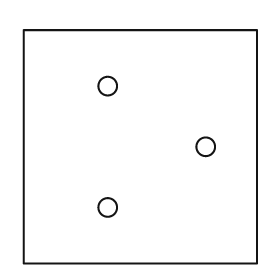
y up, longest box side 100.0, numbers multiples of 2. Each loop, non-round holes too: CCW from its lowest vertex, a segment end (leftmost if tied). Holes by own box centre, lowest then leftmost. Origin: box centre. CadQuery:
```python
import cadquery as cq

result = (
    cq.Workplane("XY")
    .moveTo(-50.0, -50.0)
    .lineTo(50.0, -50.0)
    .lineTo(50.0, 50.0)
    .lineTo(-50.0, 50.0)
    .close()
    .moveTo(-14.0, -26.0)
    .circle(4.0)
    .moveTo(28.0, 0.0)
    .circle(4.0)
    .moveTo(-14.0, 26.0)
    .circle(4.0)
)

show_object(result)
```